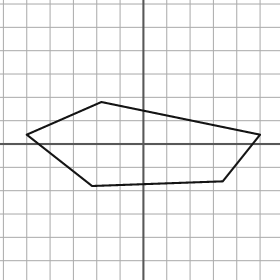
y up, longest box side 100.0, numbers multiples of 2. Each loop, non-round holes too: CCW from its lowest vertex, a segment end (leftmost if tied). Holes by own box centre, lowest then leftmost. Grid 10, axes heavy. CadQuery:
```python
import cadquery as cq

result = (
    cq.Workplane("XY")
    .moveTo(-22.0, -18.0)
    .lineTo(34.0, -16.0)
    .lineTo(50.0, 4.0)
    .lineTo(-18.0, 18.0)
    .lineTo(-50.0, 4.0)
    .close()
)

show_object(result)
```